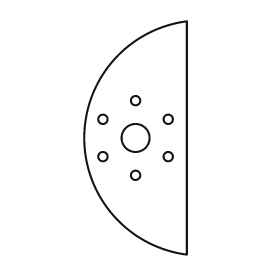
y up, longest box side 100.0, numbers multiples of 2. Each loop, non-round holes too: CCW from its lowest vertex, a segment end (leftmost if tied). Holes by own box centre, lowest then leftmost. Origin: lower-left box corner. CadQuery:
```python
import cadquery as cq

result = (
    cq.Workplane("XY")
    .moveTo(44.0, 0.0)
    .lineTo(44.0, 100.0)
    .threePointArc((0.0, 50.0), (44.0, 0.0))
    .close()
    .moveTo(22.0, 34.0)
    .circle(2.0)
    .moveTo(8.0, 42.0)
    .circle(2.0)
    .moveTo(36.0, 42.0)
    .circle(2.0)
    .moveTo(22.0, 50.0)
    .circle(6.0)
    .moveTo(8.0, 58.0)
    .circle(2.0)
    .moveTo(36.0, 58.0)
    .circle(2.0)
    .moveTo(22.0, 66.0)
    .circle(2.0)
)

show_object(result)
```